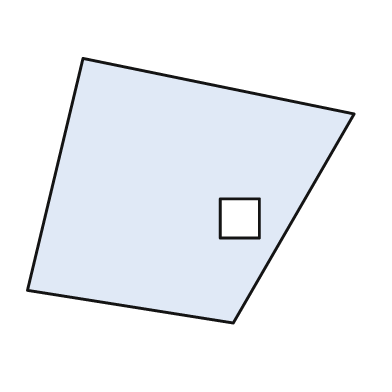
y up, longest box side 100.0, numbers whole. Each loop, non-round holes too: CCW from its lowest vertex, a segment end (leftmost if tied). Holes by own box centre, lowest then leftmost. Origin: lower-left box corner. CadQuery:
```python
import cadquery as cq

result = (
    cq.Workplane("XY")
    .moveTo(63.0, 0.0)
    .lineTo(100.0, 64.0)
    .lineTo(17.0, 81.0)
    .lineTo(0.0, 10.0)
    .close()
    .moveTo(59.0, 26.0)
    .lineTo(71.0, 26.0)
    .lineTo(71.0, 38.0)
    .lineTo(59.0, 38.0)
    .close()
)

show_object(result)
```